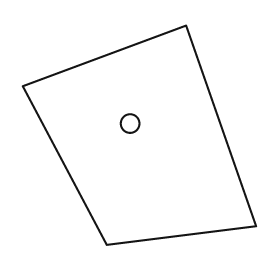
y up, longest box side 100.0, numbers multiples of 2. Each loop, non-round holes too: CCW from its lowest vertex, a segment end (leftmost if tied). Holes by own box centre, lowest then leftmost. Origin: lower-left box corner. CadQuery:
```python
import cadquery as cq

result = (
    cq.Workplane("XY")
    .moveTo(36.0, 0.0)
    .lineTo(100.0, 8.0)
    .lineTo(70.0, 94.0)
    .lineTo(0.0, 68.0)
    .close()
    .moveTo(46.0, 52.0)
    .circle(4.0)
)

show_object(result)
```